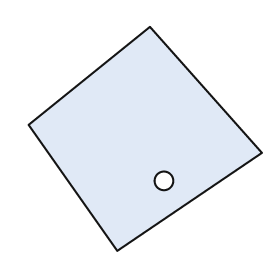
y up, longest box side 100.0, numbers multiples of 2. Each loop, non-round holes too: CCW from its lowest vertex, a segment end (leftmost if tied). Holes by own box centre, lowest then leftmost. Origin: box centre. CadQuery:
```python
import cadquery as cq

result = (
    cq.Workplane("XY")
    .moveTo(-12.0, -48.0)
    .lineTo(50.0, -6.0)
    .lineTo(2.0, 48.0)
    .lineTo(-50.0, 6.0)
    .close()
    .moveTo(8.0, -18.0)
    .circle(4.0)
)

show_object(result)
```